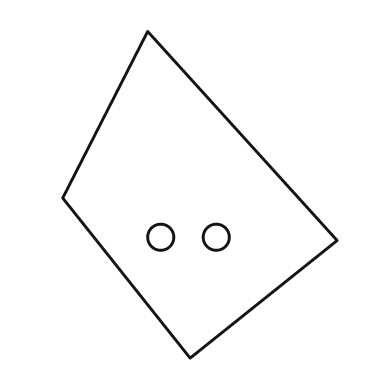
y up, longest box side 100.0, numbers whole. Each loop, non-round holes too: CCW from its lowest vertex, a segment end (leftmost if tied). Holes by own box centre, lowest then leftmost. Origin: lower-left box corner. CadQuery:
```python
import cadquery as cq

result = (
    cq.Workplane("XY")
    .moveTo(39.0, 0.0)
    .lineTo(84.0, 36.0)
    .lineTo(26.0, 100.0)
    .lineTo(0.0, 49.0)
    .close()
    .moveTo(30.0, 37.0)
    .circle(4.0)
    .moveTo(47.0, 37.0)
    .circle(4.0)
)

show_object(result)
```